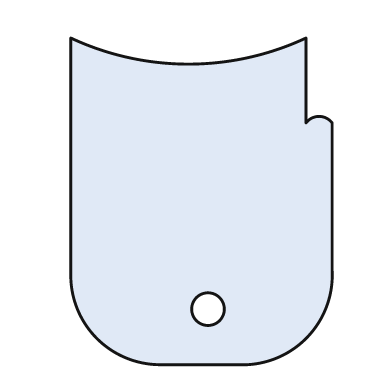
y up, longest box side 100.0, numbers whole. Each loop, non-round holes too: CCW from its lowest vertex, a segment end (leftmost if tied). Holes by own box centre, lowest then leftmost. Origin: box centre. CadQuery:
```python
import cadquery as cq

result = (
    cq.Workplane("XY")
    .moveTo(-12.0, -50.0)
    .lineTo(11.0, -50.0)
    .threePointArc((32.0, -42.0), (40.0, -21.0))
    .lineTo(40.0, 24.0)
    .threePointArc((36.0, 26.0), (32.0, 24.0))
    .lineTo(32.0, 50.0)
    .threePointArc((-4.0, 42.0), (-40.0, 50.0))
    .lineTo(-40.0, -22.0)
    .threePointArc((-32.0, -42.0), (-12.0, -50.0))
    .close()
    .moveTo(2.0, -33.0)
    .circle(5.0)
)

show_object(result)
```